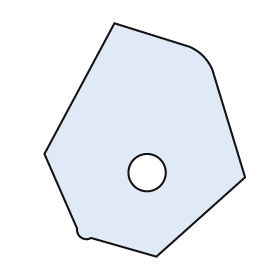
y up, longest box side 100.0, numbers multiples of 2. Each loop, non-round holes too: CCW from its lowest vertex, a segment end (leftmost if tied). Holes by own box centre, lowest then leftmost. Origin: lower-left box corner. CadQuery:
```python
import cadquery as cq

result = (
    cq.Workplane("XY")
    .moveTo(48.0, 0.0)
    .lineTo(86.0, 34.0)
    .lineTo(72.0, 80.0)
    .threePointArc((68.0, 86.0), (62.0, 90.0))
    .lineTo(30.0, 100.0)
    .lineTo(0.0, 44.0)
    .lineTo(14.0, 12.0)
    .threePointArc((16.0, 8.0), (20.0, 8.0))
    .close()
    .moveTo(44.0, 36.0)
    .circle(8.0)
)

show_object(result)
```